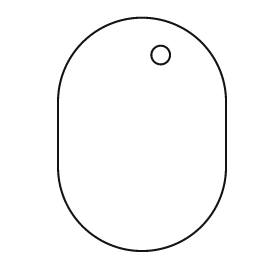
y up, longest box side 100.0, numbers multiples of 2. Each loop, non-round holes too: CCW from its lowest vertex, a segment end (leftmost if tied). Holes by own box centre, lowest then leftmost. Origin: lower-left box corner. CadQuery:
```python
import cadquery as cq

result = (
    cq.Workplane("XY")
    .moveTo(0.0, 36.0)
    .threePointArc((36.0, 0.0), (72.0, 36.0))
    .lineTo(72.0, 64.0)
    .threePointArc((36.0, 100.0), (0.0, 64.0))
    .close()
    .moveTo(44.0, 84.0)
    .circle(4.0)
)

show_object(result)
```